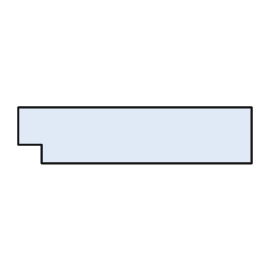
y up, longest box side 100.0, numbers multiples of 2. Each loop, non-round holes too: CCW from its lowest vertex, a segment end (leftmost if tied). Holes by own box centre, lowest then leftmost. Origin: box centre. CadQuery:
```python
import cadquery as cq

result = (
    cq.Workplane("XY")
    .moveTo(-40.0, -12.0)
    .lineTo(50.0, -12.0)
    .lineTo(50.0, 12.0)
    .lineTo(-50.0, 12.0)
    .lineTo(-50.0, -4.0)
    .lineTo(-40.0, -4.0)
    .close()
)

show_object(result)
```